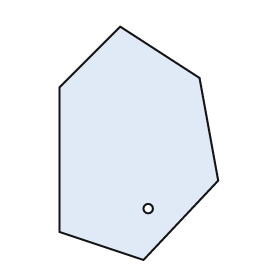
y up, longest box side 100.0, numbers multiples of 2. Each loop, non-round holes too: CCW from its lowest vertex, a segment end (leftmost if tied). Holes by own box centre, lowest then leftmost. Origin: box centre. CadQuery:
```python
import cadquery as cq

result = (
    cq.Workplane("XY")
    .moveTo(2.0, -50.0)
    .lineTo(34.0, -16.0)
    .lineTo(26.0, 28.0)
    .lineTo(-8.0, 50.0)
    .lineTo(-34.0, 24.0)
    .lineTo(-34.0, -38.0)
    .close()
    .moveTo(4.0, -28.0)
    .circle(2.0)
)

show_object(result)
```